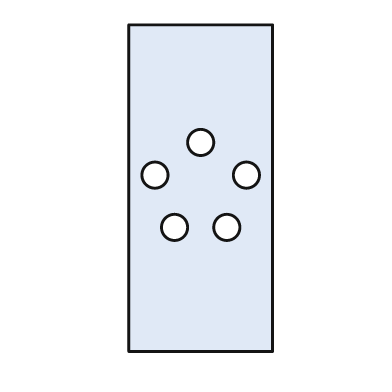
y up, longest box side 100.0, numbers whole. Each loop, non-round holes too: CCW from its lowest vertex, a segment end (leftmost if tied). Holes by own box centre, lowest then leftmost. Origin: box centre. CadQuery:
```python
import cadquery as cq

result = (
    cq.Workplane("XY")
    .moveTo(-22.0, -50.0)
    .lineTo(22.0, -50.0)
    .lineTo(22.0, 50.0)
    .lineTo(-22.0, 50.0)
    .close()
    .moveTo(-8.0, -12.0)
    .circle(4.0)
    .moveTo(8.0, -12.0)
    .circle(4.0)
    .moveTo(-14.0, 4.0)
    .circle(4.0)
    .moveTo(14.0, 4.0)
    .circle(4.0)
    .moveTo(0.0, 14.0)
    .circle(4.0)
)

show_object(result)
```